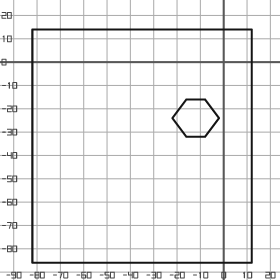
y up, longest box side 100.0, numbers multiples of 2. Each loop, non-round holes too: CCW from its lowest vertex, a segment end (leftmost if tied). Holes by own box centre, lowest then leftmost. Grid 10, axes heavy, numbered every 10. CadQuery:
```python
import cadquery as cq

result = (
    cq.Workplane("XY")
    .moveTo(-82.0, -86.0)
    .lineTo(12.0, -86.0)
    .lineTo(12.0, 14.0)
    .lineTo(-82.0, 14.0)
    .close()
    .moveTo(-16.0, -32.0)
    .lineTo(-8.0, -32.0)
    .lineTo(-2.0, -24.0)
    .lineTo(-8.0, -16.0)
    .lineTo(-16.0, -16.0)
    .lineTo(-22.0, -24.0)
    .close()
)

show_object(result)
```